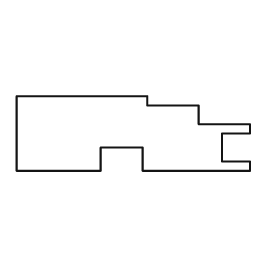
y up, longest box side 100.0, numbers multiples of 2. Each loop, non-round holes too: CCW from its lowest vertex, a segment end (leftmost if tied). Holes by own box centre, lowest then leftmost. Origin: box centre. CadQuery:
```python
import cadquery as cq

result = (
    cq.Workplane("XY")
    .moveTo(-50.0, -16.0)
    .lineTo(-14.0, -16.0)
    .lineTo(-14.0, -6.0)
    .lineTo(4.0, -6.0)
    .lineTo(4.0, -16.0)
    .lineTo(50.0, -16.0)
    .lineTo(50.0, -12.0)
    .lineTo(38.0, -12.0)
    .lineTo(38.0, 0.0)
    .lineTo(50.0, 0.0)
    .lineTo(50.0, 4.0)
    .lineTo(28.0, 4.0)
    .lineTo(28.0, 12.0)
    .lineTo(6.0, 12.0)
    .lineTo(6.0, 16.0)
    .lineTo(-50.0, 16.0)
    .close()
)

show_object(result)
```